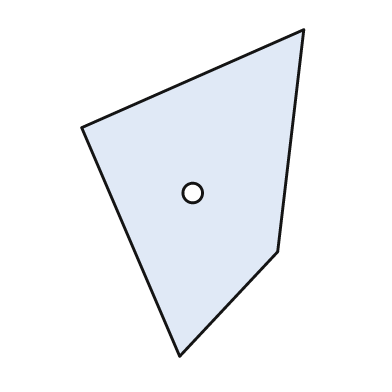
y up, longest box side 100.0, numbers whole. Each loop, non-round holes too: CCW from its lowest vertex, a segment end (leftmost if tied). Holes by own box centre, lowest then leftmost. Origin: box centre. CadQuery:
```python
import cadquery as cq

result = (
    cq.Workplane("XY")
    .moveTo(-4.0, -50.0)
    .lineTo(26.0, -18.0)
    .lineTo(34.0, 50.0)
    .lineTo(-34.0, 20.0)
    .close()
    .moveTo(0.0, 0.0)
    .circle(3.0)
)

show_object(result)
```